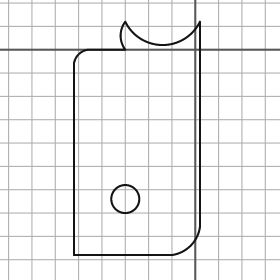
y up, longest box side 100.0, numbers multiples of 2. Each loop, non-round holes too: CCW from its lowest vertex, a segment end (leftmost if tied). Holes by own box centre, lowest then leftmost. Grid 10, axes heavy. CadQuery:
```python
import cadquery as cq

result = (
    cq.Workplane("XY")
    .moveTo(-52.0, -88.0)
    .lineTo(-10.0, -88.0)
    .threePointArc((-2.0, -84.0), (2.0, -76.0))
    .lineTo(2.0, 12.0)
    .threePointArc((-14.0, 2.0), (-30.0, 12.0))
    .threePointArc((-32.0, 6.0), (-30.0, 0.0))
    .lineTo(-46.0, 0.0)
    .threePointArc((-50.0, -2.0), (-52.0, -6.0))
    .close()
    .moveTo(-30.0, -64.0)
    .circle(6.0)
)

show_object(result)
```